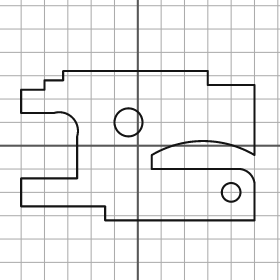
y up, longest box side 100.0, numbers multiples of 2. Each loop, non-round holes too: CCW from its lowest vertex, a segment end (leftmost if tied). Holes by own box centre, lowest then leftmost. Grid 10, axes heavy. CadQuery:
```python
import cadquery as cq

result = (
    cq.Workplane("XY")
    .moveTo(-14.0, -32.0)
    .lineTo(50.0, -32.0)
    .lineTo(50.0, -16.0)
    .threePointArc((48.0, -12.0), (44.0, -10.0))
    .lineTo(6.0, -10.0)
    .lineTo(6.0, -4.0)
    .threePointArc((28.0, 2.0), (50.0, -4.0))
    .lineTo(50.0, 26.0)
    .lineTo(30.0, 26.0)
    .lineTo(30.0, 32.0)
    .lineTo(-32.0, 32.0)
    .lineTo(-32.0, 28.0)
    .lineTo(-40.0, 28.0)
    .lineTo(-40.0, 24.0)
    .lineTo(-50.0, 24.0)
    .lineTo(-50.0, 14.0)
    .lineTo(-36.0, 14.0)
    .threePointArc((-28.0, 12.0), (-26.0, 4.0))
    .lineTo(-26.0, -14.0)
    .lineTo(-50.0, -14.0)
    .lineTo(-50.0, -26.0)
    .lineTo(-14.0, -26.0)
    .close()
    .moveTo(40.0, -20.0)
    .circle(4.0)
    .moveTo(-4.0, 10.0)
    .circle(6.0)
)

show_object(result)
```